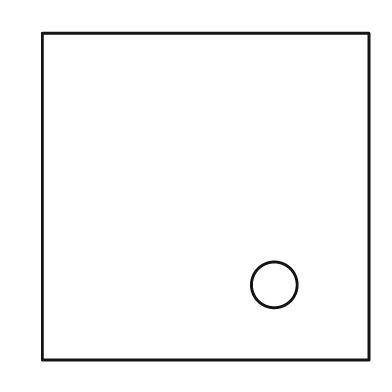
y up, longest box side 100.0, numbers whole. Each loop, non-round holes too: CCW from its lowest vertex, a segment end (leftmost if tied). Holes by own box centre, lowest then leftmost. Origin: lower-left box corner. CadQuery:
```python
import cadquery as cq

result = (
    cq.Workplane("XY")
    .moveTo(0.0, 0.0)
    .lineTo(100.0, 0.0)
    .lineTo(100.0, 100.0)
    .lineTo(0.0, 100.0)
    .close()
    .moveTo(71.0, 23.0)
    .circle(7.0)
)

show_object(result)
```